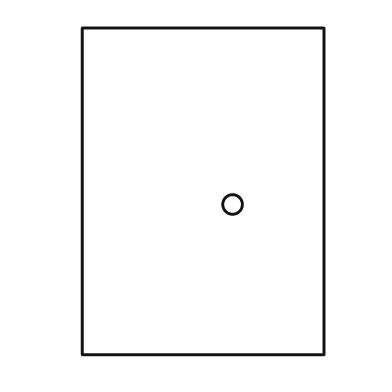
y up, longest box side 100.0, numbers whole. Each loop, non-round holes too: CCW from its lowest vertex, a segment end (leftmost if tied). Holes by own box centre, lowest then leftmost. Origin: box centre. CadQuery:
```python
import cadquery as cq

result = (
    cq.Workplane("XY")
    .moveTo(-37.0, -50.0)
    .lineTo(37.0, -50.0)
    .lineTo(37.0, 50.0)
    .lineTo(-37.0, 50.0)
    .close()
    .moveTo(9.0, -4.0)
    .circle(3.0)
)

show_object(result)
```